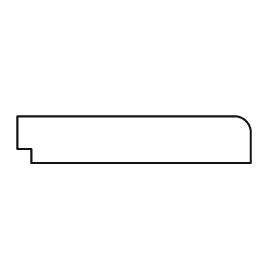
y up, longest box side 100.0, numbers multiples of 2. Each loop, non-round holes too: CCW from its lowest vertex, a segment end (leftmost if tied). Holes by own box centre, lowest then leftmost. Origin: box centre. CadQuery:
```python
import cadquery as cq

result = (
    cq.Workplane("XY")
    .moveTo(-44.0, -10.0)
    .lineTo(50.0, -10.0)
    .lineTo(50.0, 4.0)
    .threePointArc((48.0, 8.0), (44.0, 10.0))
    .lineTo(-50.0, 10.0)
    .lineTo(-50.0, -4.0)
    .lineTo(-44.0, -4.0)
    .close()
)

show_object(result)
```